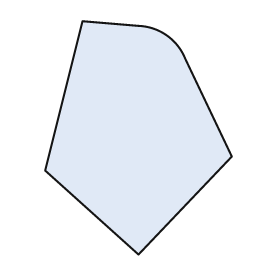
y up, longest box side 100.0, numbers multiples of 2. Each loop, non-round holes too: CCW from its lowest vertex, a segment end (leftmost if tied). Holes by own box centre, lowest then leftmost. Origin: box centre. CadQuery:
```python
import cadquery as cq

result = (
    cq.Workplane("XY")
    .moveTo(0.0, -50.0)
    .lineTo(40.0, -8.0)
    .lineTo(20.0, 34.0)
    .threePointArc((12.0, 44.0), (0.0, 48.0))
    .lineTo(-24.0, 50.0)
    .lineTo(-40.0, -14.0)
    .close()
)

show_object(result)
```